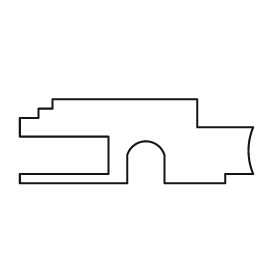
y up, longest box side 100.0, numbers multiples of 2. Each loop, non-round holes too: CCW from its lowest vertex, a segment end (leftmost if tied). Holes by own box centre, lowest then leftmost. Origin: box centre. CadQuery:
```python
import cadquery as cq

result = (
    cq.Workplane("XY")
    .moveTo(-50.0, -18.0)
    .lineTo(-4.0, -18.0)
    .lineTo(-4.0, -6.0)
    .threePointArc((4.0, 0.0), (12.0, -6.0))
    .lineTo(12.0, -18.0)
    .lineTo(38.0, -18.0)
    .lineTo(38.0, -14.0)
    .lineTo(50.0, -14.0)
    .threePointArc((48.0, -4.0), (50.0, 6.0))
    .lineTo(26.0, 6.0)
    .lineTo(26.0, 18.0)
    .lineTo(-36.0, 18.0)
    .lineTo(-36.0, 14.0)
    .lineTo(-42.0, 14.0)
    .lineTo(-42.0, 10.0)
    .lineTo(-50.0, 10.0)
    .lineTo(-50.0, 2.0)
    .lineTo(-12.0, 2.0)
    .lineTo(-12.0, -14.0)
    .lineTo(-50.0, -14.0)
    .close()
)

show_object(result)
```